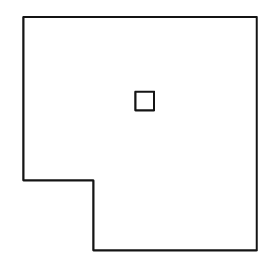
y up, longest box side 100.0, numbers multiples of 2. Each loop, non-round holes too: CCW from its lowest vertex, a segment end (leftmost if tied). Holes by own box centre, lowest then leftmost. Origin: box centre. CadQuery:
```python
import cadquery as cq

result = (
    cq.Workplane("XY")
    .moveTo(-20.0, -50.0)
    .lineTo(50.0, -50.0)
    .lineTo(50.0, 50.0)
    .lineTo(-50.0, 50.0)
    .lineTo(-50.0, -20.0)
    .lineTo(-20.0, -20.0)
    .close()
    .moveTo(-2.0, 10.0)
    .lineTo(6.0, 10.0)
    .lineTo(6.0, 18.0)
    .lineTo(-2.0, 18.0)
    .close()
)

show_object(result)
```